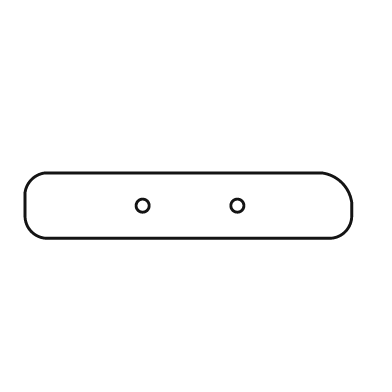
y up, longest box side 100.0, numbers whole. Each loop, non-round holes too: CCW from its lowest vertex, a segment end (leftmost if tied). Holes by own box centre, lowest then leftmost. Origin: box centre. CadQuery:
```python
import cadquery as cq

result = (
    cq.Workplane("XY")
    .moveTo(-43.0, -10.0)
    .lineTo(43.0, -10.0)
    .threePointArc((48.0, -8.0), (50.0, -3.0))
    .lineTo(50.0, 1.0)
    .threePointArc((47.0, 7.0), (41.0, 10.0))
    .lineTo(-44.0, 10.0)
    .threePointArc((-48.0, 8.0), (-50.0, 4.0))
    .lineTo(-50.0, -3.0)
    .threePointArc((-48.0, -8.0), (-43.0, -10.0))
    .close()
    .moveTo(-14.0, 0.0)
    .circle(2.0)
    .moveTo(15.0, 0.0)
    .circle(2.0)
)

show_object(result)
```